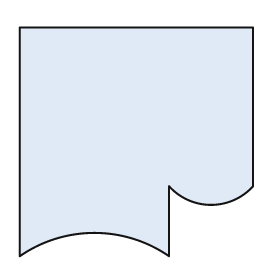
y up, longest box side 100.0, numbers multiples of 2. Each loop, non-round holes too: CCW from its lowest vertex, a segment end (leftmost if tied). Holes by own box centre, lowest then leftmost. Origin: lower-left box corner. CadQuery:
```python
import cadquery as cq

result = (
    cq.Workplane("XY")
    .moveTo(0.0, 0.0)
    .threePointArc((32.0, 10.0), (64.0, 0.0))
    .lineTo(64.0, 30.0)
    .threePointArc((82.0, 22.0), (100.0, 30.0))
    .lineTo(100.0, 98.0)
    .lineTo(0.0, 98.0)
    .close()
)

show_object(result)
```